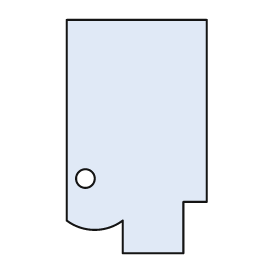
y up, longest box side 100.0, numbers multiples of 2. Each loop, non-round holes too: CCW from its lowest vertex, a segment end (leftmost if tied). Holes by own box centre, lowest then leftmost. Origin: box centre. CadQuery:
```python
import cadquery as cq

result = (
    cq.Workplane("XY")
    .moveTo(-6.0, -50.0)
    .lineTo(20.0, -50.0)
    .lineTo(20.0, -28.0)
    .lineTo(30.0, -28.0)
    .lineTo(30.0, 50.0)
    .lineTo(-30.0, 50.0)
    .lineTo(-30.0, -36.0)
    .threePointArc((-18.0, -40.0), (-6.0, -36.0))
    .close()
    .moveTo(-22.0, -18.0)
    .circle(4.0)
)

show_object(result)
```